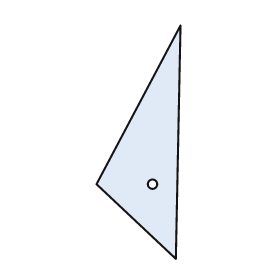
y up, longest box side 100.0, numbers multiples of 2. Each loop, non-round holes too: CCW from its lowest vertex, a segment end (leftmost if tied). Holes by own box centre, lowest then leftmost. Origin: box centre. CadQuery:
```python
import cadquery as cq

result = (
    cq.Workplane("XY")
    .moveTo(16.0, -50.0)
    .lineTo(18.0, 50.0)
    .lineTo(-18.0, -18.0)
    .close()
    .moveTo(6.0, -18.0)
    .circle(2.0)
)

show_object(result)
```